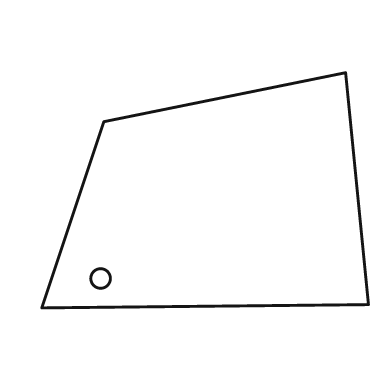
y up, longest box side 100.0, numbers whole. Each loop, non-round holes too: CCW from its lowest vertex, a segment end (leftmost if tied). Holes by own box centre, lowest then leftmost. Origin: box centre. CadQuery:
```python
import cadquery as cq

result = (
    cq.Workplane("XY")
    .moveTo(-50.0, -36.0)
    .lineTo(50.0, -35.0)
    .lineTo(43.0, 36.0)
    .lineTo(-31.0, 21.0)
    .close()
    .moveTo(-32.0, -27.0)
    .circle(3.0)
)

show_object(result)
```